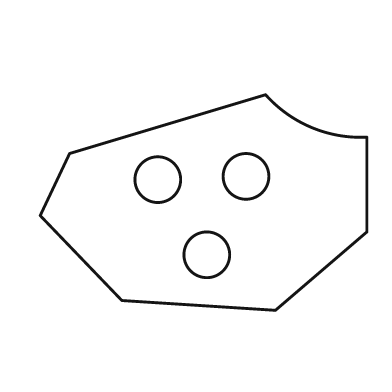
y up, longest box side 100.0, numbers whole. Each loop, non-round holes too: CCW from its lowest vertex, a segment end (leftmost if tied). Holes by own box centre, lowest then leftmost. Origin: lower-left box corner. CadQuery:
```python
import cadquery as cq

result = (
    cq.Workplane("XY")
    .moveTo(72.0, 0.0)
    .lineTo(100.0, 24.0)
    .lineTo(100.0, 53.0)
    .threePointArc((83.0, 56.0), (69.0, 66.0))
    .lineTo(9.0, 48.0)
    .lineTo(0.0, 29.0)
    .lineTo(25.0, 3.0)
    .close()
    .moveTo(51.0, 17.0)
    .circle(7.0)
    .moveTo(36.0, 40.0)
    .circle(7.0)
    .moveTo(63.0, 41.0)
    .circle(7.0)
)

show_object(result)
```